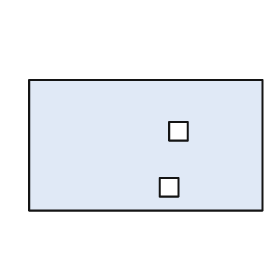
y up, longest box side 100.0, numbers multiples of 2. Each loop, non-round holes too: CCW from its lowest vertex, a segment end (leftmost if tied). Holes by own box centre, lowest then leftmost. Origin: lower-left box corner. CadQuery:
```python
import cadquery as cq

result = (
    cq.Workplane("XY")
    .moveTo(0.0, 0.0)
    .lineTo(100.0, 0.0)
    .lineTo(100.0, 56.0)
    .lineTo(0.0, 56.0)
    .close()
    .moveTo(56.0, 6.0)
    .lineTo(64.0, 6.0)
    .lineTo(64.0, 14.0)
    .lineTo(56.0, 14.0)
    .close()
    .moveTo(60.0, 30.0)
    .lineTo(68.0, 30.0)
    .lineTo(68.0, 38.0)
    .lineTo(60.0, 38.0)
    .close()
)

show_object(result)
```